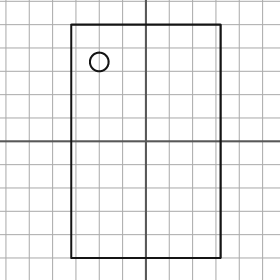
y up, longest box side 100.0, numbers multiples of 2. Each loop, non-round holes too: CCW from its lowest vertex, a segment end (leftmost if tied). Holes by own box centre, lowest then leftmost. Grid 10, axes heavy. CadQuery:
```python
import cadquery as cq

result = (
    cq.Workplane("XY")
    .moveTo(-32.0, -50.0)
    .lineTo(32.0, -50.0)
    .lineTo(32.0, 50.0)
    .lineTo(-32.0, 50.0)
    .close()
    .moveTo(-20.0, 34.0)
    .circle(4.0)
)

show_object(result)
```